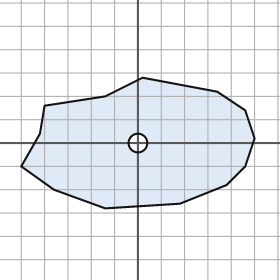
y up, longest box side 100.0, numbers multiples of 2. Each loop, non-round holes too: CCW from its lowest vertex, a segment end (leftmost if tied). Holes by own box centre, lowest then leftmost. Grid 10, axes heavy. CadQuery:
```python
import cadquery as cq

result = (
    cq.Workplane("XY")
    .moveTo(-14.0, -28.0)
    .lineTo(18.0, -26.0)
    .lineTo(38.0, -18.0)
    .lineTo(46.0, -10.0)
    .lineTo(50.0, 2.0)
    .lineTo(46.0, 14.0)
    .lineTo(34.0, 22.0)
    .lineTo(2.0, 28.0)
    .lineTo(-14.0, 20.0)
    .lineTo(-40.0, 16.0)
    .lineTo(-42.0, 4.0)
    .lineTo(-50.0, -10.0)
    .lineTo(-36.0, -20.0)
    .close()
    .moveTo(0.0, 0.0)
    .circle(4.0)
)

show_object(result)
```